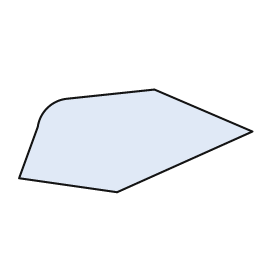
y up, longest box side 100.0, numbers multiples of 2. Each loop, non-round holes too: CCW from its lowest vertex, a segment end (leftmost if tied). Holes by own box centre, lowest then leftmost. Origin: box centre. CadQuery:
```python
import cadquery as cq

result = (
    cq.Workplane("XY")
    .moveTo(-8.0, -22.0)
    .lineTo(50.0, 4.0)
    .lineTo(8.0, 22.0)
    .lineTo(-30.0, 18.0)
    .threePointArc((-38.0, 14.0), (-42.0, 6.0))
    .lineTo(-50.0, -16.0)
    .close()
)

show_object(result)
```